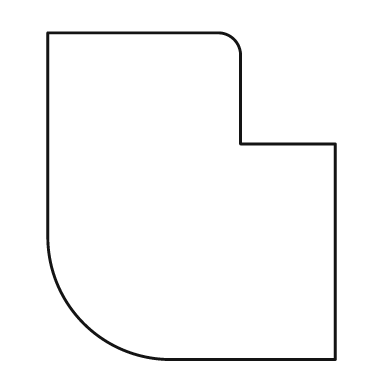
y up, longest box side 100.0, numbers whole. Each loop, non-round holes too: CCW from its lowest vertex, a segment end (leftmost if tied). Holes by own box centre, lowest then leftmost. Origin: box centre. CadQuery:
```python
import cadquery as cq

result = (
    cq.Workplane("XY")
    .moveTo(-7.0, -50.0)
    .lineTo(44.0, -50.0)
    .lineTo(44.0, 16.0)
    .lineTo(15.0, 16.0)
    .lineTo(15.0, 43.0)
    .threePointArc((13.0, 48.0), (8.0, 50.0))
    .lineTo(-44.0, 50.0)
    .lineTo(-44.0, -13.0)
    .threePointArc((-33.0, -39.0), (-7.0, -50.0))
    .close()
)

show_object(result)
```